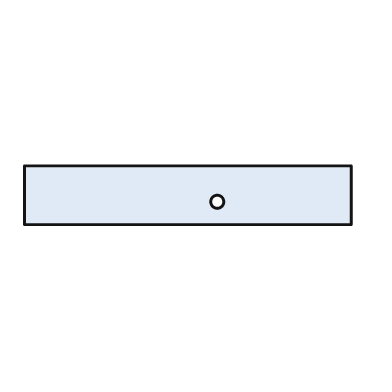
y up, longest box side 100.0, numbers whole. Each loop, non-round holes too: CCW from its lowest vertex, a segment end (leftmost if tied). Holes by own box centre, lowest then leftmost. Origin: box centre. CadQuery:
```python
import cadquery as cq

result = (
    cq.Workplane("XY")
    .moveTo(-50.0, -9.0)
    .lineTo(50.0, -9.0)
    .lineTo(50.0, 9.0)
    .lineTo(-50.0, 9.0)
    .close()
    .moveTo(9.0, -2.0)
    .circle(2.0)
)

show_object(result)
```